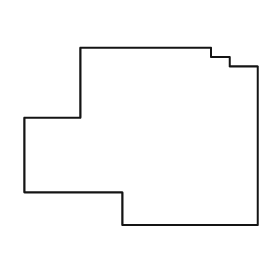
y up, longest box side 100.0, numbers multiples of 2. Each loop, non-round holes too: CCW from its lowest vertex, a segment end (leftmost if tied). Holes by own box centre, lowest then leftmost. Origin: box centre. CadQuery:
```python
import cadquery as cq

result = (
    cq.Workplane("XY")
    .moveTo(-8.0, -38.0)
    .lineTo(50.0, -38.0)
    .lineTo(50.0, 30.0)
    .lineTo(38.0, 30.0)
    .lineTo(38.0, 34.0)
    .lineTo(30.0, 34.0)
    .lineTo(30.0, 38.0)
    .lineTo(-26.0, 38.0)
    .lineTo(-26.0, 8.0)
    .lineTo(-50.0, 8.0)
    .lineTo(-50.0, -24.0)
    .lineTo(-8.0, -24.0)
    .close()
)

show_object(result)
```